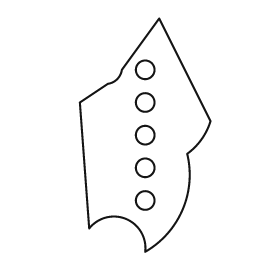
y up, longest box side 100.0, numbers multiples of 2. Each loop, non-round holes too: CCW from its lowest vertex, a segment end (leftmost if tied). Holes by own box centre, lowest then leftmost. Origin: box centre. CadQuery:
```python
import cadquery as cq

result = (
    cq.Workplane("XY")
    .moveTo(0.0, -50.0)
    .threePointArc((16.0, -32.0), (18.0, -8.0))
    .threePointArc((24.0, -2.0), (28.0, 6.0))
    .lineTo(6.0, 50.0)
    .lineTo(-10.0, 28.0)
    .threePointArc((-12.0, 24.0), (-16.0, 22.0))
    .lineTo(-28.0, 14.0)
    .lineTo(-24.0, -40.0)
    .threePointArc((-8.0, -36.0), (0.0, -50.0))
    .close()
    .moveTo(0.0, -28.0)
    .circle(4.0)
    .moveTo(0.0, -14.0)
    .circle(4.0)
    .moveTo(0.0, 0.0)
    .circle(4.0)
    .moveTo(0.0, 14.0)
    .circle(4.0)
    .moveTo(0.0, 28.0)
    .circle(4.0)
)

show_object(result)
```